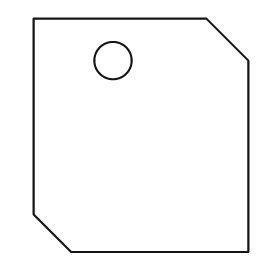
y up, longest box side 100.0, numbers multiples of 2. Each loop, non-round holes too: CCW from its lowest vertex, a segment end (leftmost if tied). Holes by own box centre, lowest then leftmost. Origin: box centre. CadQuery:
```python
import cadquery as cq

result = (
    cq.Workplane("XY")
    .moveTo(-30.0, -50.0)
    .lineTo(46.0, -50.0)
    .lineTo(46.0, 32.0)
    .lineTo(28.0, 50.0)
    .lineTo(-46.0, 50.0)
    .lineTo(-46.0, -34.0)
    .close()
    .moveTo(-12.0, 32.0)
    .circle(8.0)
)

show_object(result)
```